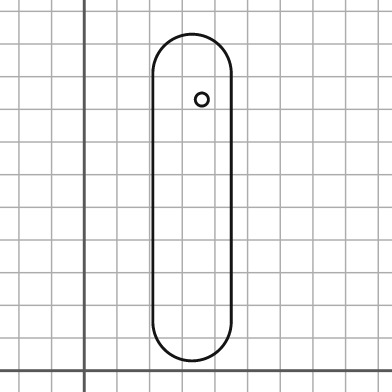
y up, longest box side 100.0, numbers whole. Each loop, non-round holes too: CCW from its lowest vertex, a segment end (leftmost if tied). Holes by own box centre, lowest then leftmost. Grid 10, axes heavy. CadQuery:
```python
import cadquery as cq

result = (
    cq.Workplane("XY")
    .moveTo(21.0, 15.0)
    .threePointArc((33.0, 3.0), (45.0, 15.0))
    .lineTo(45.0, 91.0)
    .threePointArc((33.0, 103.0), (21.0, 91.0))
    .close()
    .moveTo(36.0, 83.0)
    .circle(2.0)
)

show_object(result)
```